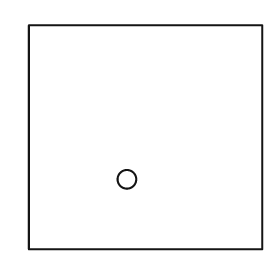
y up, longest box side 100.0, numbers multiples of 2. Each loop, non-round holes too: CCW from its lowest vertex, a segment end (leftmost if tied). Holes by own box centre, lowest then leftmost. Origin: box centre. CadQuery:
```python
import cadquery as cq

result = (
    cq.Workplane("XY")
    .moveTo(-50.0, -48.0)
    .lineTo(50.0, -48.0)
    .lineTo(50.0, 48.0)
    .lineTo(-50.0, 48.0)
    .close()
    .moveTo(-8.0, -18.0)
    .circle(4.0)
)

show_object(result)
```